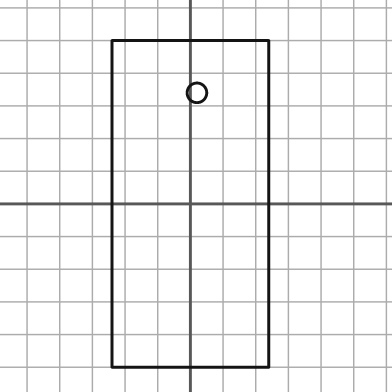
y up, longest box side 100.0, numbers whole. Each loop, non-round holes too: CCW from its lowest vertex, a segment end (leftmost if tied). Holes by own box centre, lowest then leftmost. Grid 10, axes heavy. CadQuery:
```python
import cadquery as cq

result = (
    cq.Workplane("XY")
    .moveTo(-24.0, -50.0)
    .lineTo(24.0, -50.0)
    .lineTo(24.0, 50.0)
    .lineTo(-24.0, 50.0)
    .close()
    .moveTo(2.0, 34.0)
    .circle(3.0)
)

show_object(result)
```